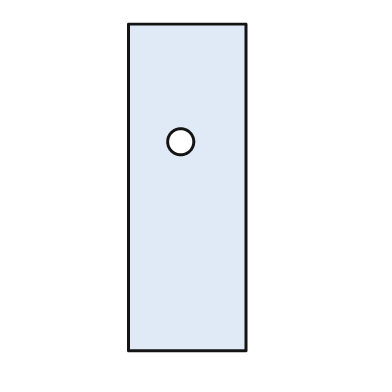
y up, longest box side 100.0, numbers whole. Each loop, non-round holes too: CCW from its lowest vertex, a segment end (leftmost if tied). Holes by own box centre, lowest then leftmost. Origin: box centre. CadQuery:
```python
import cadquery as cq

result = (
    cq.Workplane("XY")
    .moveTo(-18.0, -50.0)
    .lineTo(18.0, -50.0)
    .lineTo(18.0, 50.0)
    .lineTo(-18.0, 50.0)
    .close()
    .moveTo(-2.0, 14.0)
    .circle(4.0)
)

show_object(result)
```